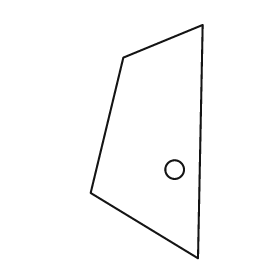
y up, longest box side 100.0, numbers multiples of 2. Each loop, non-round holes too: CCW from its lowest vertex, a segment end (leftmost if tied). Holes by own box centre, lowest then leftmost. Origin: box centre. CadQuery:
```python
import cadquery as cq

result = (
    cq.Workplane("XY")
    .moveTo(22.0, -50.0)
    .lineTo(24.0, 50.0)
    .lineTo(-10.0, 36.0)
    .lineTo(-24.0, -22.0)
    .close()
    .moveTo(12.0, -12.0)
    .circle(4.0)
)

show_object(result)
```